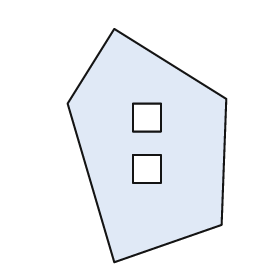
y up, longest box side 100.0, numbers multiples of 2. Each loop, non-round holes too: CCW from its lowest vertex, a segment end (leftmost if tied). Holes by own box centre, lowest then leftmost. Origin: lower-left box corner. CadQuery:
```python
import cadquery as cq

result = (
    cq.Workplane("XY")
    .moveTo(20.0, 0.0)
    .lineTo(66.0, 16.0)
    .lineTo(68.0, 70.0)
    .lineTo(20.0, 100.0)
    .lineTo(0.0, 68.0)
    .close()
    .moveTo(28.0, 34.0)
    .lineTo(40.0, 34.0)
    .lineTo(40.0, 46.0)
    .lineTo(28.0, 46.0)
    .close()
    .moveTo(28.0, 56.0)
    .lineTo(40.0, 56.0)
    .lineTo(40.0, 68.0)
    .lineTo(28.0, 68.0)
    .close()
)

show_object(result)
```